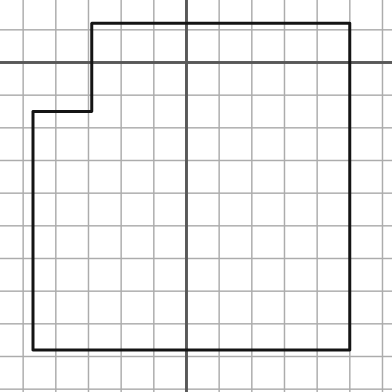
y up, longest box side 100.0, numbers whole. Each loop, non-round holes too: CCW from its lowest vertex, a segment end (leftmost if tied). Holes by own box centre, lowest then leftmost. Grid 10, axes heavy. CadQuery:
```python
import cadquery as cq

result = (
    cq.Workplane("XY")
    .moveTo(-47.0, -88.0)
    .lineTo(50.0, -88.0)
    .lineTo(50.0, 12.0)
    .lineTo(-29.0, 12.0)
    .lineTo(-29.0, -15.0)
    .lineTo(-47.0, -15.0)
    .close()
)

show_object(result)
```